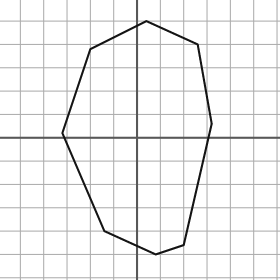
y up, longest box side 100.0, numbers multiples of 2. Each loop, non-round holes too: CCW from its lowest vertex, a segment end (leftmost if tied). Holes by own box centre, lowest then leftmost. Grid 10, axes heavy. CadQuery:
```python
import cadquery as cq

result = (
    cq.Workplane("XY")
    .moveTo(8.0, -50.0)
    .lineTo(20.0, -46.0)
    .lineTo(32.0, 6.0)
    .lineTo(26.0, 40.0)
    .lineTo(4.0, 50.0)
    .lineTo(-20.0, 38.0)
    .lineTo(-32.0, 2.0)
    .lineTo(-14.0, -40.0)
    .close()
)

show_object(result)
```